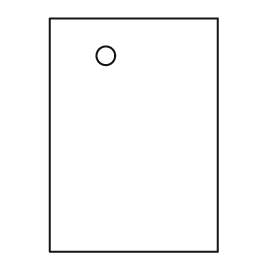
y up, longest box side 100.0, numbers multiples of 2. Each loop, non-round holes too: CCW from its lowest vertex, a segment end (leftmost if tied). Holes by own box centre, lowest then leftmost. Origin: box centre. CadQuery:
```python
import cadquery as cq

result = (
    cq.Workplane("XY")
    .moveTo(-36.0, -50.0)
    .lineTo(36.0, -50.0)
    .lineTo(36.0, 50.0)
    .lineTo(-36.0, 50.0)
    .close()
    .moveTo(-12.0, 34.0)
    .circle(4.0)
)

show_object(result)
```